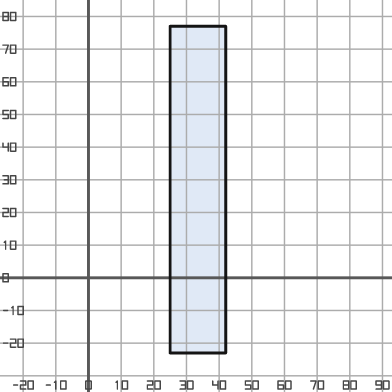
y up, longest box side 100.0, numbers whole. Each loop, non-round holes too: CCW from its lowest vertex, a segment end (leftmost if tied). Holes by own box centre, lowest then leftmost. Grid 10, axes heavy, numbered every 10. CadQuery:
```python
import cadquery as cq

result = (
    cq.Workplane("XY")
    .moveTo(25.0, -23.0)
    .lineTo(42.0, -23.0)
    .lineTo(42.0, 77.0)
    .lineTo(25.0, 77.0)
    .close()
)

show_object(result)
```